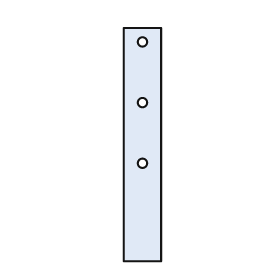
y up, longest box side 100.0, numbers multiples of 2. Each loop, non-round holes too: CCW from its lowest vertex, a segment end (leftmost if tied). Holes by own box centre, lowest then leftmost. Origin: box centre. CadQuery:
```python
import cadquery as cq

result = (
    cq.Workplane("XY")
    .moveTo(-8.0, -50.0)
    .lineTo(8.0, -50.0)
    .lineTo(8.0, 50.0)
    .lineTo(-8.0, 50.0)
    .close()
    .moveTo(0.0, -8.0)
    .circle(2.0)
    .moveTo(0.0, 18.0)
    .circle(2.0)
    .moveTo(0.0, 44.0)
    .circle(2.0)
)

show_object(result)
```